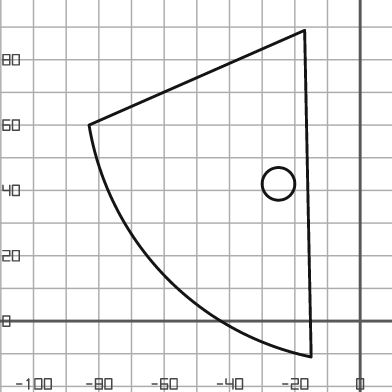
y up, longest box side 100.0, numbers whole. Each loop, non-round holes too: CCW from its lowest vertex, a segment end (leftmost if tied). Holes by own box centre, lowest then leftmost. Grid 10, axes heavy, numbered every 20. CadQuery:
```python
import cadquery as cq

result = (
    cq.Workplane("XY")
    .moveTo(-15.0, -11.0)
    .lineTo(-17.0, 89.0)
    .lineTo(-83.0, 60.0)
    .threePointArc((-60.0, 14.0), (-15.0, -11.0))
    .close()
    .moveTo(-25.0, 42.0)
    .circle(5.0)
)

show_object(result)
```